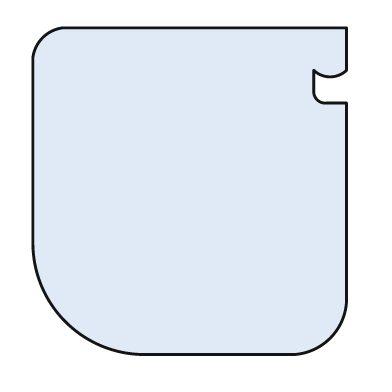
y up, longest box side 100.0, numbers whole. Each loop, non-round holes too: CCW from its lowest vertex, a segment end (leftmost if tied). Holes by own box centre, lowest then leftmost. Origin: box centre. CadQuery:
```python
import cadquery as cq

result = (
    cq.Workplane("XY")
    .moveTo(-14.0, -50.0)
    .lineTo(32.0, -50.0)
    .threePointArc((43.0, -45.0), (48.0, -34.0))
    .lineTo(48.0, 27.0)
    .lineTo(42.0, 27.0)
    .threePointArc((39.0, 28.0), (38.0, 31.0))
    .lineTo(38.0, 37.0)
    .threePointArc((43.0, 35.0), (48.0, 37.0))
    .lineTo(48.0, 50.0)
    .lineTo(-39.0, 50.0)
    .threePointArc((-45.0, 47.0), (-48.0, 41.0))
    .lineTo(-48.0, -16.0)
    .threePointArc((-38.0, -40.0), (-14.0, -50.0))
    .close()
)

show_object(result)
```